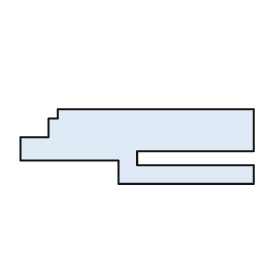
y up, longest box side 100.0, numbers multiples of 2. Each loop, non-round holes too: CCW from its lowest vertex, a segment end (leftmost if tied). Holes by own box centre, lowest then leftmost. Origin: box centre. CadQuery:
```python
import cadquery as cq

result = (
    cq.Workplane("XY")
    .moveTo(-8.0, -16.0)
    .lineTo(50.0, -16.0)
    .lineTo(50.0, -8.0)
    .lineTo(0.0, -8.0)
    .lineTo(0.0, -2.0)
    .lineTo(50.0, -2.0)
    .lineTo(50.0, 16.0)
    .lineTo(-34.0, 16.0)
    .lineTo(-34.0, 12.0)
    .lineTo(-38.0, 12.0)
    .lineTo(-38.0, 4.0)
    .lineTo(-50.0, 4.0)
    .lineTo(-50.0, -6.0)
    .lineTo(-8.0, -6.0)
    .close()
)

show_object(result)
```